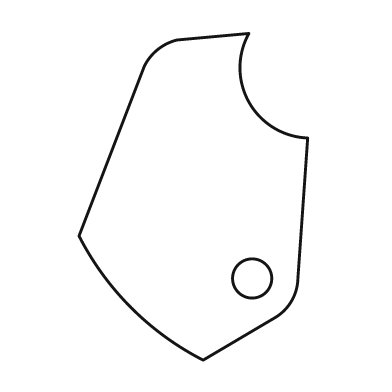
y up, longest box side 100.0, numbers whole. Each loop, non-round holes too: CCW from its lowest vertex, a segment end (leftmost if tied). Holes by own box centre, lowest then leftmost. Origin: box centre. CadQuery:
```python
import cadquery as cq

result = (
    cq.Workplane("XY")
    .moveTo(3.0, -50.0)
    .lineTo(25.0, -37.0)
    .threePointArc((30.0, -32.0), (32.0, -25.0))
    .lineTo(35.0, 18.0)
    .threePointArc((17.0, 29.0), (17.0, 50.0))
    .lineTo(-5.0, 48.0)
    .threePointArc((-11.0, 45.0), (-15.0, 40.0))
    .lineTo(-35.0, -12.0)
    .threePointArc((-19.0, -34.0), (3.0, -50.0))
    .close()
    .moveTo(18.0, -25.0)
    .circle(6.0)
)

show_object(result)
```